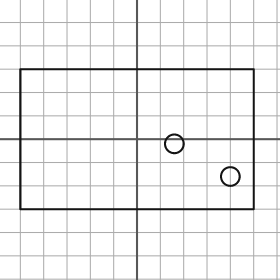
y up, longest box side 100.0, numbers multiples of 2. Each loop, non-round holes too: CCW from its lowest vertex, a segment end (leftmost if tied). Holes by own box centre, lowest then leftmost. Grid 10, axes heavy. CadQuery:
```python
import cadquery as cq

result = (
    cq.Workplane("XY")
    .moveTo(-50.0, -30.0)
    .lineTo(50.0, -30.0)
    .lineTo(50.0, 30.0)
    .lineTo(-50.0, 30.0)
    .close()
    .moveTo(40.0, -16.0)
    .circle(4.0)
    .moveTo(16.0, -2.0)
    .circle(4.0)
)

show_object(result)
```